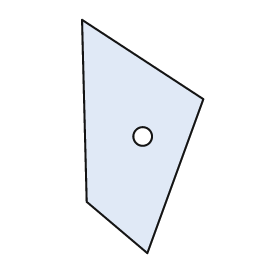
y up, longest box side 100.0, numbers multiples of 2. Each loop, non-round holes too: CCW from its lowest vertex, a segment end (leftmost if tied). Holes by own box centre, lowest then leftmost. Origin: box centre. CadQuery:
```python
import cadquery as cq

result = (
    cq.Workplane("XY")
    .moveTo(2.0, -50.0)
    .lineTo(26.0, 16.0)
    .lineTo(-26.0, 50.0)
    .lineTo(-24.0, -28.0)
    .close()
    .moveTo(0.0, 0.0)
    .circle(4.0)
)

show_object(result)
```